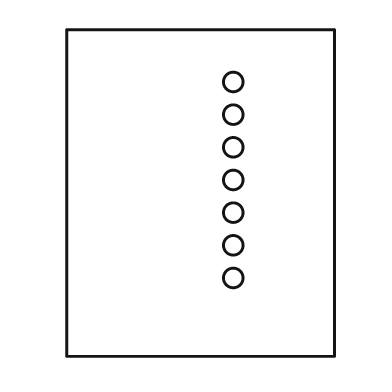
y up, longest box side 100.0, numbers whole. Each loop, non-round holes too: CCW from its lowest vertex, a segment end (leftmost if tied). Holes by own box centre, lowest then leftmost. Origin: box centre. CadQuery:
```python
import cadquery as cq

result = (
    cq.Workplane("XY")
    .moveTo(-41.0, -50.0)
    .lineTo(41.0, -50.0)
    .lineTo(41.0, 50.0)
    .lineTo(-41.0, 50.0)
    .close()
    .moveTo(10.0, -26.0)
    .circle(3.0)
    .moveTo(10.0, -16.0)
    .circle(3.0)
    .moveTo(10.0, -6.0)
    .circle(3.0)
    .moveTo(10.0, 4.0)
    .circle(3.0)
    .moveTo(10.0, 14.0)
    .circle(3.0)
    .moveTo(10.0, 24.0)
    .circle(3.0)
    .moveTo(10.0, 34.0)
    .circle(3.0)
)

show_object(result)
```